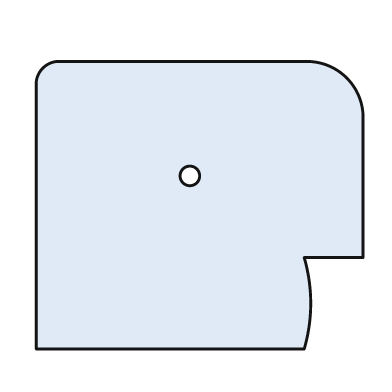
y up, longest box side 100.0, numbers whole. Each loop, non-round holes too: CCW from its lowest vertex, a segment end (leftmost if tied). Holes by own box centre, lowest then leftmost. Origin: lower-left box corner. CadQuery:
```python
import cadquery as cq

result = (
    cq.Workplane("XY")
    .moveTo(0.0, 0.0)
    .lineTo(82.0, 0.0)
    .threePointArc((84.0, 14.0), (82.0, 28.0))
    .lineTo(100.0, 28.0)
    .lineTo(100.0, 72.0)
    .threePointArc((95.0, 83.0), (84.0, 88.0))
    .lineTo(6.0, 88.0)
    .threePointArc((2.0, 86.0), (0.0, 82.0))
    .close()
    .moveTo(47.0, 53.0)
    .circle(3.0)
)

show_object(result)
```